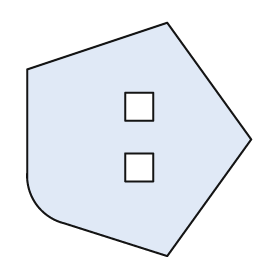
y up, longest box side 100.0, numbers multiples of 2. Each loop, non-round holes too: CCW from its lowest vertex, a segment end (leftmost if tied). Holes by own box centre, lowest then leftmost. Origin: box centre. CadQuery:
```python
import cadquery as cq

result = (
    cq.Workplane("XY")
    .moveTo(12.0, -50.0)
    .lineTo(48.0, 0.0)
    .lineTo(12.0, 50.0)
    .lineTo(-48.0, 30.0)
    .lineTo(-48.0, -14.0)
    .threePointArc((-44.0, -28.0), (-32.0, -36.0))
    .close()
    .moveTo(-6.0, -18.0)
    .lineTo(6.0, -18.0)
    .lineTo(6.0, -6.0)
    .lineTo(-6.0, -6.0)
    .close()
    .moveTo(-6.0, 8.0)
    .lineTo(6.0, 8.0)
    .lineTo(6.0, 20.0)
    .lineTo(-6.0, 20.0)
    .close()
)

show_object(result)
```